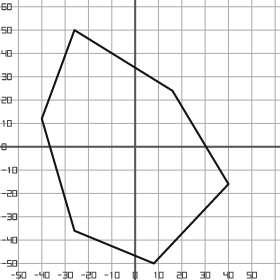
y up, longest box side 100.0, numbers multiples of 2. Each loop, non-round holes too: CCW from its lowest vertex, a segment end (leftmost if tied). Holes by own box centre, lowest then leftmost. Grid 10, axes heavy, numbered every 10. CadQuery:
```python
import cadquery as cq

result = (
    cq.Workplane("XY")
    .moveTo(8.0, -50.0)
    .lineTo(40.0, -16.0)
    .lineTo(16.0, 24.0)
    .lineTo(-26.0, 50.0)
    .lineTo(-40.0, 12.0)
    .lineTo(-26.0, -36.0)
    .close()
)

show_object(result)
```